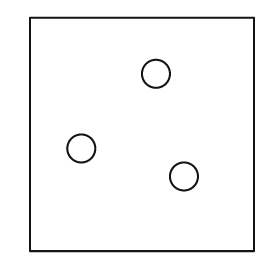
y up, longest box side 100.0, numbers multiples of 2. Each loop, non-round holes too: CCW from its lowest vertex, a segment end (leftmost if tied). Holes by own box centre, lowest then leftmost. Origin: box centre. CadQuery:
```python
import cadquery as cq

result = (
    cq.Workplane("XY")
    .moveTo(-48.0, -50.0)
    .lineTo(48.0, -50.0)
    .lineTo(48.0, 50.0)
    .lineTo(-48.0, 50.0)
    .close()
    .moveTo(18.0, -18.0)
    .circle(6.0)
    .moveTo(-26.0, -6.0)
    .circle(6.0)
    .moveTo(6.0, 26.0)
    .circle(6.0)
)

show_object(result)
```